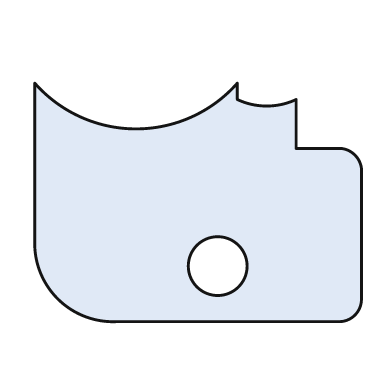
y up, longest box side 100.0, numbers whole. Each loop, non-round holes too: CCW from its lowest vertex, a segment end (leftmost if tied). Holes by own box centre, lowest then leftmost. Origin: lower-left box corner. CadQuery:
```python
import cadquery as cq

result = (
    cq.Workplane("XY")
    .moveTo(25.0, 0.0)
    .lineTo(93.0, 0.0)
    .threePointArc((98.0, 2.0), (100.0, 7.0))
    .lineTo(100.0, 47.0)
    .threePointArc((98.0, 51.0), (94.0, 53.0))
    .lineTo(80.0, 53.0)
    .lineTo(80.0, 68.0)
    .threePointArc((71.0, 66.0), (62.0, 68.0))
    .lineTo(62.0, 73.0)
    .threePointArc((31.0, 59.0), (0.0, 73.0))
    .lineTo(0.0, 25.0)
    .threePointArc((7.0, 7.0), (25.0, 0.0))
    .close()
    .moveTo(56.0, 17.0)
    .circle(9.0)
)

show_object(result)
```